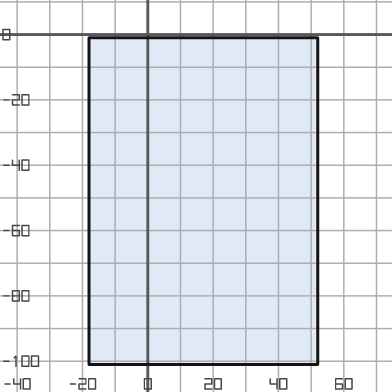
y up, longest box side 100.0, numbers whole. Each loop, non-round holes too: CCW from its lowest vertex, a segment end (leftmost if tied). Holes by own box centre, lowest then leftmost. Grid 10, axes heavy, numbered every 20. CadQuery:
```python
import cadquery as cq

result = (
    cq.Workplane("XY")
    .moveTo(-18.0, -101.0)
    .lineTo(52.0, -101.0)
    .lineTo(52.0, -1.0)
    .lineTo(-18.0, -1.0)
    .close()
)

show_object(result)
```